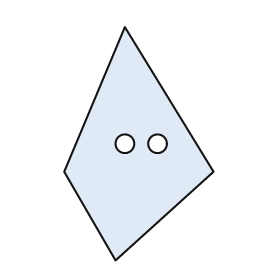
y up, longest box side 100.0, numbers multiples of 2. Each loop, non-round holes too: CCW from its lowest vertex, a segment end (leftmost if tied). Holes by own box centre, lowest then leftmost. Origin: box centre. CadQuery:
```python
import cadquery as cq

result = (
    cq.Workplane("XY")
    .moveTo(-10.0, -50.0)
    .lineTo(32.0, -12.0)
    .lineTo(-6.0, 50.0)
    .lineTo(-32.0, -12.0)
    .close()
    .moveTo(-6.0, 0.0)
    .circle(4.0)
    .moveTo(8.0, 0.0)
    .circle(4.0)
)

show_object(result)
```